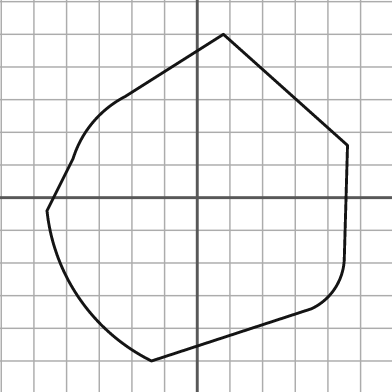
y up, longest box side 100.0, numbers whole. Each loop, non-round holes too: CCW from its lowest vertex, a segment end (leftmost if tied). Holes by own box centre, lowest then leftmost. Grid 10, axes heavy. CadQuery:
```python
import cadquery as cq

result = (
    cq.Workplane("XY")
    .moveTo(-14.0, -50.0)
    .lineTo(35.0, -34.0)
    .threePointArc((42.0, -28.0), (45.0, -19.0))
    .lineTo(46.0, 16.0)
    .lineTo(8.0, 50.0)
    .lineTo(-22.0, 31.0)
    .threePointArc((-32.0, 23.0), (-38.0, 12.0))
    .lineTo(-46.0, -4.0)
    .threePointArc((-36.0, -31.0), (-14.0, -50.0))
    .close()
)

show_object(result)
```